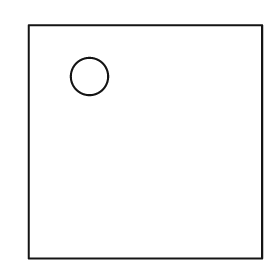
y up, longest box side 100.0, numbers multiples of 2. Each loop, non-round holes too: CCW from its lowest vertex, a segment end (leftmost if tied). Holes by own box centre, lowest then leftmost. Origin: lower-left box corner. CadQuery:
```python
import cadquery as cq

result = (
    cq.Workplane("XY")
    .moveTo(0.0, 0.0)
    .lineTo(100.0, 0.0)
    .lineTo(100.0, 100.0)
    .lineTo(0.0, 100.0)
    .close()
    .moveTo(26.0, 78.0)
    .circle(8.0)
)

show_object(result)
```